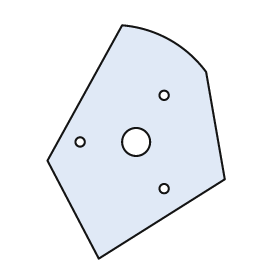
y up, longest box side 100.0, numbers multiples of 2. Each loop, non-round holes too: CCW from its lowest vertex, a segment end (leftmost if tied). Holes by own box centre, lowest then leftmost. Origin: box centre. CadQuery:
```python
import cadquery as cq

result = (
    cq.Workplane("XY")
    .moveTo(-16.0, -50.0)
    .lineTo(38.0, -16.0)
    .lineTo(30.0, 30.0)
    .threePointArc((14.0, 44.0), (-6.0, 50.0))
    .lineTo(-38.0, -8.0)
    .close()
    .moveTo(12.0, -20.0)
    .circle(2.0)
    .moveTo(-24.0, 0.0)
    .circle(2.0)
    .moveTo(0.0, 0.0)
    .circle(6.0)
    .moveTo(12.0, 20.0)
    .circle(2.0)
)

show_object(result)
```